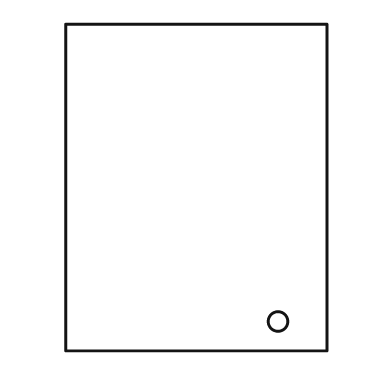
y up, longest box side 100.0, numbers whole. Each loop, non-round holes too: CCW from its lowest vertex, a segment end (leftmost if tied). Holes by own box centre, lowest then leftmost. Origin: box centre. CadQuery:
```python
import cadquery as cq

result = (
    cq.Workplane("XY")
    .moveTo(-40.0, -50.0)
    .lineTo(40.0, -50.0)
    .lineTo(40.0, 50.0)
    .lineTo(-40.0, 50.0)
    .close()
    .moveTo(25.0, -41.0)
    .circle(3.0)
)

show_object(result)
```